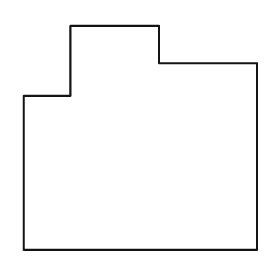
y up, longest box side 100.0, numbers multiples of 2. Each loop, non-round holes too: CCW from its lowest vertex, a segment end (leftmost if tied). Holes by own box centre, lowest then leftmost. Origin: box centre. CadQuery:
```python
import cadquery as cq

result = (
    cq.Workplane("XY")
    .moveTo(-50.0, -48.0)
    .lineTo(50.0, -48.0)
    .lineTo(50.0, 32.0)
    .lineTo(8.0, 32.0)
    .lineTo(8.0, 48.0)
    .lineTo(-30.0, 48.0)
    .lineTo(-30.0, 18.0)
    .lineTo(-50.0, 18.0)
    .close()
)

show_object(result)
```